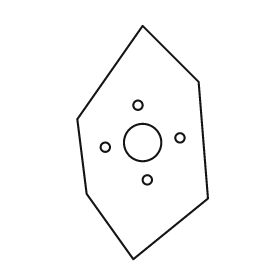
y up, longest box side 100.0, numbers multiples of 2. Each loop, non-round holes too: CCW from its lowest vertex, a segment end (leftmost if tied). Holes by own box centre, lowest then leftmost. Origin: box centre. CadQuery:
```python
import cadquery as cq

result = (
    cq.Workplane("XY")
    .moveTo(-4.0, -50.0)
    .lineTo(28.0, -24.0)
    .lineTo(24.0, 26.0)
    .lineTo(0.0, 50.0)
    .lineTo(-28.0, 10.0)
    .lineTo(-24.0, -22.0)
    .close()
    .moveTo(2.0, -16.0)
    .circle(2.0)
    .moveTo(-16.0, -2.0)
    .circle(2.0)
    .moveTo(0.0, 0.0)
    .circle(8.0)
    .moveTo(16.0, 2.0)
    .circle(2.0)
    .moveTo(-2.0, 16.0)
    .circle(2.0)
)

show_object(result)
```